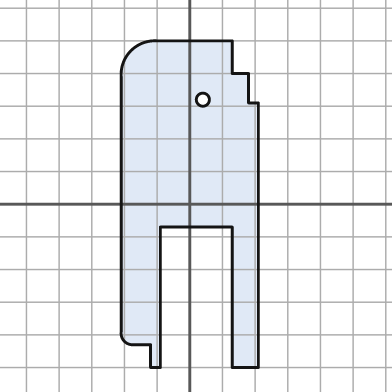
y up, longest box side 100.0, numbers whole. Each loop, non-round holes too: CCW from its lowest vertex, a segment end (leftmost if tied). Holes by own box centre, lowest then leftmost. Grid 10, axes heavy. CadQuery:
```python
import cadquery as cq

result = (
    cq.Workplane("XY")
    .moveTo(-12.0, -50.0)
    .lineTo(-9.0, -50.0)
    .lineTo(-9.0, -7.0)
    .lineTo(13.0, -7.0)
    .lineTo(13.0, -50.0)
    .lineTo(21.0, -50.0)
    .lineTo(21.0, 31.0)
    .lineTo(18.0, 31.0)
    .lineTo(18.0, 40.0)
    .lineTo(13.0, 40.0)
    .lineTo(13.0, 50.0)
    .lineTo(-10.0, 50.0)
    .threePointArc((-18.0, 47.0), (-21.0, 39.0))
    .lineTo(-21.0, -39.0)
    .threePointArc((-20.0, -42.0), (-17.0, -43.0))
    .lineTo(-12.0, -43.0)
    .close()
    .moveTo(4.0, 32.0)
    .circle(2.0)
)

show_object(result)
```